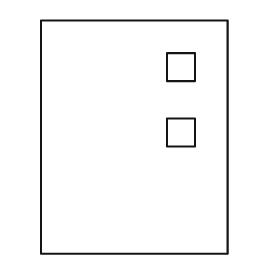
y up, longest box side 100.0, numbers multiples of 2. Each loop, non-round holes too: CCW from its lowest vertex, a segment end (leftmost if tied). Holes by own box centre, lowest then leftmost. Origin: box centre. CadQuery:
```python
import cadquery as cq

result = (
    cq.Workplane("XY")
    .moveTo(-40.0, -50.0)
    .lineTo(40.0, -50.0)
    .lineTo(40.0, 50.0)
    .lineTo(-40.0, 50.0)
    .close()
    .moveTo(14.0, -4.0)
    .lineTo(26.0, -4.0)
    .lineTo(26.0, 8.0)
    .lineTo(14.0, 8.0)
    .close()
    .moveTo(14.0, 24.0)
    .lineTo(26.0, 24.0)
    .lineTo(26.0, 36.0)
    .lineTo(14.0, 36.0)
    .close()
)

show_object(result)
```